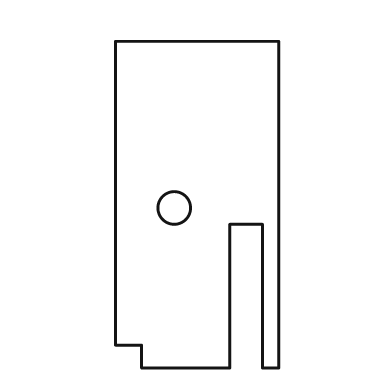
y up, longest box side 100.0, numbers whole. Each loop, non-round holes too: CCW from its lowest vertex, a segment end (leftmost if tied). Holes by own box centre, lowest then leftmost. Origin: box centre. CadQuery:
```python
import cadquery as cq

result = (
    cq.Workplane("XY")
    .moveTo(-17.0, -50.0)
    .lineTo(10.0, -50.0)
    .lineTo(10.0, -6.0)
    .lineTo(20.0, -6.0)
    .lineTo(20.0, -50.0)
    .lineTo(25.0, -50.0)
    .lineTo(25.0, 50.0)
    .lineTo(-25.0, 50.0)
    .lineTo(-25.0, -43.0)
    .lineTo(-17.0, -43.0)
    .close()
    .moveTo(-7.0, -1.0)
    .circle(5.0)
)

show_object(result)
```